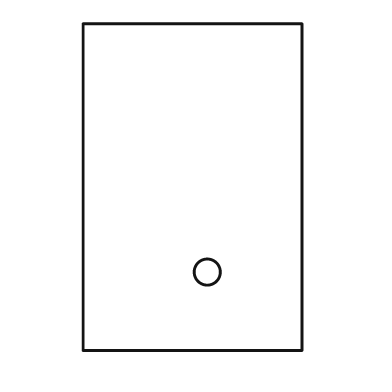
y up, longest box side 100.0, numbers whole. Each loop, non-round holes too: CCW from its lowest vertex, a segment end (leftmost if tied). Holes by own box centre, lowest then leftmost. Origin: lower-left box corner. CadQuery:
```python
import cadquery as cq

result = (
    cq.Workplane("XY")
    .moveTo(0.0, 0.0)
    .lineTo(67.0, 0.0)
    .lineTo(67.0, 100.0)
    .lineTo(0.0, 100.0)
    .close()
    .moveTo(38.0, 24.0)
    .circle(4.0)
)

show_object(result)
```